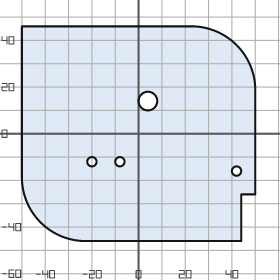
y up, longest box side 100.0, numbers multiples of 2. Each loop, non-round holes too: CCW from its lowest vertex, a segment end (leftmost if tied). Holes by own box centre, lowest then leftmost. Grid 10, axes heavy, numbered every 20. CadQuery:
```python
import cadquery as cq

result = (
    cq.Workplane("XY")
    .moveTo(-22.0, -46.0)
    .lineTo(44.0, -46.0)
    .lineTo(44.0, -26.0)
    .lineTo(50.0, -26.0)
    .lineTo(50.0, 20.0)
    .threePointArc((42.0, 38.0), (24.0, 46.0))
    .lineTo(-50.0, 46.0)
    .lineTo(-50.0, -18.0)
    .threePointArc((-42.0, -38.0), (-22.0, -46.0))
    .close()
    .moveTo(42.0, -16.0)
    .circle(2.0)
    .moveTo(-20.0, -12.0)
    .circle(2.0)
    .moveTo(-8.0, -12.0)
    .circle(2.0)
    .moveTo(4.0, 14.0)
    .circle(4.0)
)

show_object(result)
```